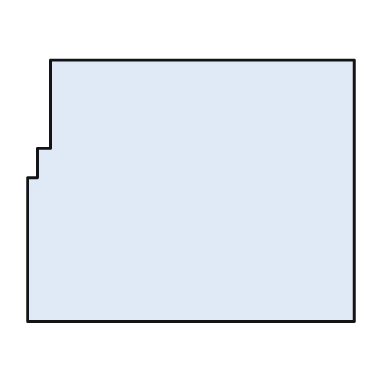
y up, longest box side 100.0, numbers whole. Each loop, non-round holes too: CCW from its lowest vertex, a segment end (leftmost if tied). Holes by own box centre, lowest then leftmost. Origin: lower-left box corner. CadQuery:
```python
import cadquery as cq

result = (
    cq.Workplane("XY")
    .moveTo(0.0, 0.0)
    .lineTo(100.0, 0.0)
    .lineTo(100.0, 80.0)
    .lineTo(7.0, 80.0)
    .lineTo(7.0, 53.0)
    .lineTo(3.0, 53.0)
    .lineTo(3.0, 44.0)
    .lineTo(0.0, 44.0)
    .close()
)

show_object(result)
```